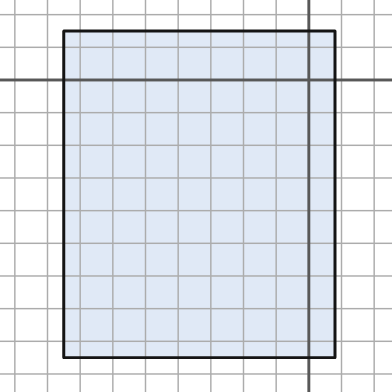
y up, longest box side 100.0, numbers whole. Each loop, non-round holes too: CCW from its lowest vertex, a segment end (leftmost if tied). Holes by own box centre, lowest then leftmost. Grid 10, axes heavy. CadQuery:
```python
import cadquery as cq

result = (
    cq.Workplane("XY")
    .moveTo(-75.0, -85.0)
    .lineTo(8.0, -85.0)
    .lineTo(8.0, 15.0)
    .lineTo(-75.0, 15.0)
    .close()
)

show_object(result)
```